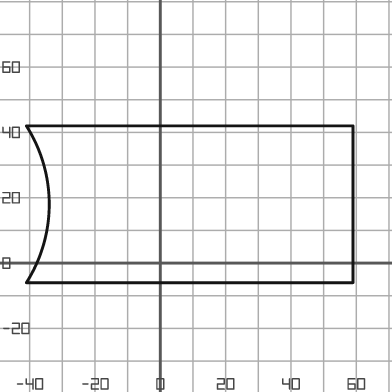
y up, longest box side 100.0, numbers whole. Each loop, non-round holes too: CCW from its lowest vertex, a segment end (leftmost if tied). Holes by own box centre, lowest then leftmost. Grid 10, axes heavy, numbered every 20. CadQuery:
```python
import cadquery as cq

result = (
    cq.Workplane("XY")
    .moveTo(-41.0, -6.0)
    .lineTo(59.0, -6.0)
    .lineTo(59.0, 42.0)
    .lineTo(-41.0, 42.0)
    .threePointArc((-34.0, 18.0), (-41.0, -6.0))
    .close()
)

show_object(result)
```